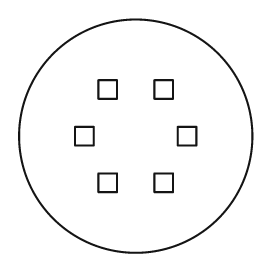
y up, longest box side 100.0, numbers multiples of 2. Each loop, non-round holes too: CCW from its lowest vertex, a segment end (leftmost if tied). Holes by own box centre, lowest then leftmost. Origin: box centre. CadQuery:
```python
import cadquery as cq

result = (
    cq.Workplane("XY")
    .moveTo(0.0, 0.0)
    .circle(50.0)
    .moveTo(-16.0, -24.0)
    .lineTo(-8.0, -24.0)
    .lineTo(-8.0, -16.0)
    .lineTo(-16.0, -16.0)
    .close()
    .moveTo(8.0, -24.0)
    .lineTo(16.0, -24.0)
    .lineTo(16.0, -16.0)
    .lineTo(8.0, -16.0)
    .close()
    .moveTo(-26.0, -4.0)
    .lineTo(-18.0, -4.0)
    .lineTo(-18.0, 4.0)
    .lineTo(-26.0, 4.0)
    .close()
    .moveTo(18.0, -4.0)
    .lineTo(26.0, -4.0)
    .lineTo(26.0, 4.0)
    .lineTo(18.0, 4.0)
    .close()
    .moveTo(-16.0, 16.0)
    .lineTo(-8.0, 16.0)
    .lineTo(-8.0, 24.0)
    .lineTo(-16.0, 24.0)
    .close()
    .moveTo(8.0, 16.0)
    .lineTo(16.0, 16.0)
    .lineTo(16.0, 24.0)
    .lineTo(8.0, 24.0)
    .close()
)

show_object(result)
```